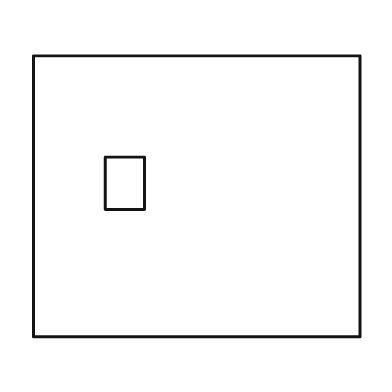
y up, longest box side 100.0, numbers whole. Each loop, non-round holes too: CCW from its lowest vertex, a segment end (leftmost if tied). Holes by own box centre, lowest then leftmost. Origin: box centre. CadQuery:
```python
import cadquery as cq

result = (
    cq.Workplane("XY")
    .moveTo(-50.0, -43.0)
    .lineTo(50.0, -43.0)
    .lineTo(50.0, 43.0)
    .lineTo(-50.0, 43.0)
    .close()
    .moveTo(-28.0, -4.0)
    .lineTo(-16.0, -4.0)
    .lineTo(-16.0, 12.0)
    .lineTo(-28.0, 12.0)
    .close()
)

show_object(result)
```